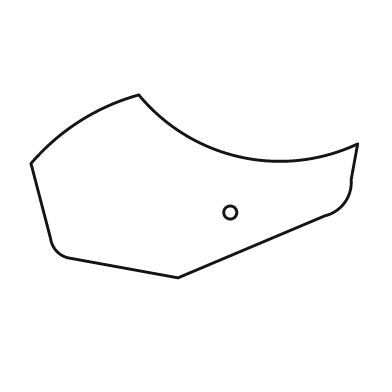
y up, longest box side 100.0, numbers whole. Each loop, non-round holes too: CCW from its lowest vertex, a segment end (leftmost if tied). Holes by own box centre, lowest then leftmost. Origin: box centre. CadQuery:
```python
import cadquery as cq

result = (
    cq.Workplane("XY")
    .moveTo(-5.0, -28.0)
    .lineTo(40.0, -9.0)
    .threePointArc((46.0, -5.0), (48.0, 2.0))
    .lineTo(50.0, 13.0)
    .threePointArc((14.0, 9.0), (-17.0, 28.0))
    .threePointArc((-35.0, 20.0), (-50.0, 7.0))
    .lineTo(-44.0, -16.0)
    .threePointArc((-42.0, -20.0), (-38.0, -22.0))
    .close()
    .moveTo(11.0, -8.0)
    .circle(2.0)
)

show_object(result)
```